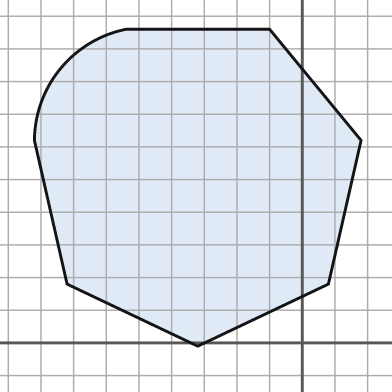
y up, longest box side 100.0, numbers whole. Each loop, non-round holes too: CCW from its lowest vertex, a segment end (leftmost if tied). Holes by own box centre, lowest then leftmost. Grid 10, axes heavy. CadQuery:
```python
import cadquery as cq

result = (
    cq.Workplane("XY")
    .moveTo(-32.0, -1.0)
    .lineTo(8.0, 18.0)
    .lineTo(18.0, 62.0)
    .lineTo(-10.0, 96.0)
    .lineTo(-54.0, 96.0)
    .threePointArc((-74.0, 84.0), (-82.0, 62.0))
    .lineTo(-72.0, 18.0)
    .close()
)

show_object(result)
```